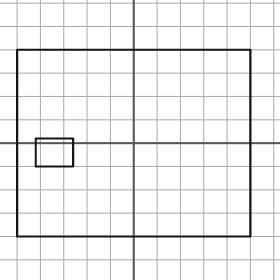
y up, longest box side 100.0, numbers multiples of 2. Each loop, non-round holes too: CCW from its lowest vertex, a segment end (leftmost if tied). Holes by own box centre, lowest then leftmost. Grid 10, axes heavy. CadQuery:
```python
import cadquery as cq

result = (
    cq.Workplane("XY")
    .moveTo(-50.0, -40.0)
    .lineTo(50.0, -40.0)
    .lineTo(50.0, 40.0)
    .lineTo(-50.0, 40.0)
    .close()
    .moveTo(-42.0, -10.0)
    .lineTo(-26.0, -10.0)
    .lineTo(-26.0, 2.0)
    .lineTo(-42.0, 2.0)
    .close()
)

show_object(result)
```